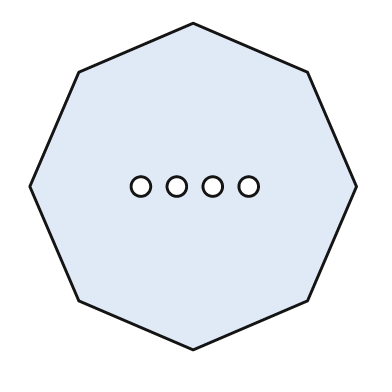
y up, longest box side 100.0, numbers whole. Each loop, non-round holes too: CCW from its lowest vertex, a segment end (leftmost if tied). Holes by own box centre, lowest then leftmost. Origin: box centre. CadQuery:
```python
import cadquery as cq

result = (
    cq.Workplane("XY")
    .moveTo(0.0, -50.0)
    .lineTo(35.0, -35.0)
    .lineTo(50.0, 0.0)
    .lineTo(35.0, 35.0)
    .lineTo(0.0, 50.0)
    .lineTo(-35.0, 35.0)
    .lineTo(-50.0, 0.0)
    .lineTo(-35.0, -35.0)
    .close()
    .moveTo(-16.0, 0.0)
    .circle(3.0)
    .moveTo(-5.0, 0.0)
    .circle(3.0)
    .moveTo(6.0, 0.0)
    .circle(3.0)
    .moveTo(17.0, 0.0)
    .circle(3.0)
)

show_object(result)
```